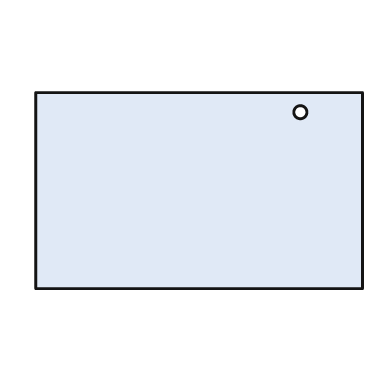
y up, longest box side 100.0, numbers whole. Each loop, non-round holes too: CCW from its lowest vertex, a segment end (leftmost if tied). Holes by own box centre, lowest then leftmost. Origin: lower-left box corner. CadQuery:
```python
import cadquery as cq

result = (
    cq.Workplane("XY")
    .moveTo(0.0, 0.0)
    .lineTo(100.0, 0.0)
    .lineTo(100.0, 60.0)
    .lineTo(0.0, 60.0)
    .close()
    .moveTo(81.0, 54.0)
    .circle(2.0)
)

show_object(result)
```